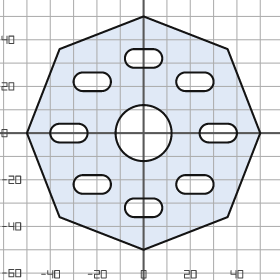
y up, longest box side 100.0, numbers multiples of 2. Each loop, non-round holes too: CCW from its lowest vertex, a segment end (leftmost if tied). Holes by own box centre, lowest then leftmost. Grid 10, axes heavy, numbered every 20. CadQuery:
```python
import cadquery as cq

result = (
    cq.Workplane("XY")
    .moveTo(0.0, -50.0)
    .lineTo(36.0, -36.0)
    .lineTo(50.0, 0.0)
    .lineTo(36.0, 36.0)
    .lineTo(0.0, 50.0)
    .lineTo(-36.0, 36.0)
    .lineTo(-50.0, 0.0)
    .lineTo(-36.0, -36.0)
    .close()
    .moveTo(-4.0, -36.0)
    .lineTo(4.0, -36.0)
    .threePointArc((8.0, -32.0), (4.0, -28.0))
    .lineTo(-4.0, -28.0)
    .threePointArc((-8.0, -32.0), (-4.0, -36.0))
    .close()
    .moveTo(-26.0, -26.0)
    .lineTo(-18.0, -26.0)
    .threePointArc((-14.0, -22.0), (-18.0, -18.0))
    .lineTo(-26.0, -18.0)
    .threePointArc((-30.0, -22.0), (-26.0, -26.0))
    .close()
    .moveTo(18.0, -26.0)
    .lineTo(26.0, -26.0)
    .threePointArc((30.0, -22.0), (26.0, -18.0))
    .lineTo(18.0, -18.0)
    .threePointArc((14.0, -22.0), (18.0, -26.0))
    .close()
    .moveTo(-36.0, -4.0)
    .lineTo(-28.0, -4.0)
    .threePointArc((-24.0, 0.0), (-28.0, 4.0))
    .lineTo(-36.0, 4.0)
    .threePointArc((-40.0, 0.0), (-36.0, -4.0))
    .close()
    .moveTo(0.0, 0.0)
    .circle(12.0)
    .moveTo(28.0, -4.0)
    .lineTo(36.0, -4.0)
    .threePointArc((40.0, 0.0), (36.0, 4.0))
    .lineTo(28.0, 4.0)
    .threePointArc((24.0, 0.0), (28.0, -4.0))
    .close()
    .moveTo(-26.0, 18.0)
    .lineTo(-18.0, 18.0)
    .threePointArc((-14.0, 22.0), (-18.0, 26.0))
    .lineTo(-26.0, 26.0)
    .threePointArc((-30.0, 22.0), (-26.0, 18.0))
    .close()
    .moveTo(18.0, 18.0)
    .lineTo(26.0, 18.0)
    .threePointArc((30.0, 22.0), (26.0, 26.0))
    .lineTo(18.0, 26.0)
    .threePointArc((14.0, 22.0), (18.0, 18.0))
    .close()
    .moveTo(-4.0, 28.0)
    .lineTo(4.0, 28.0)
    .threePointArc((8.0, 32.0), (4.0, 36.0))
    .lineTo(-4.0, 36.0)
    .threePointArc((-8.0, 32.0), (-4.0, 28.0))
    .close()
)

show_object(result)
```